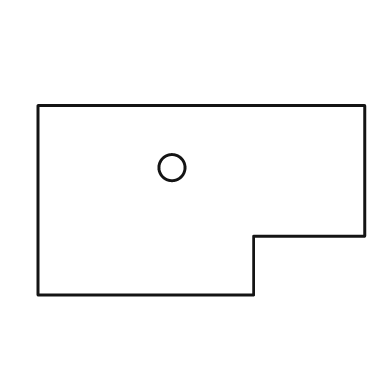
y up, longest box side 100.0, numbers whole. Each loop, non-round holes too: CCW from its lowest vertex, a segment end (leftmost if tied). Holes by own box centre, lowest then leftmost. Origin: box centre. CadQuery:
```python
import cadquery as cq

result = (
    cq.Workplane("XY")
    .moveTo(-50.0, -29.0)
    .lineTo(16.0, -29.0)
    .lineTo(16.0, -11.0)
    .lineTo(50.0, -11.0)
    .lineTo(50.0, 29.0)
    .lineTo(-50.0, 29.0)
    .close()
    .moveTo(-9.0, 10.0)
    .circle(4.0)
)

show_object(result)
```